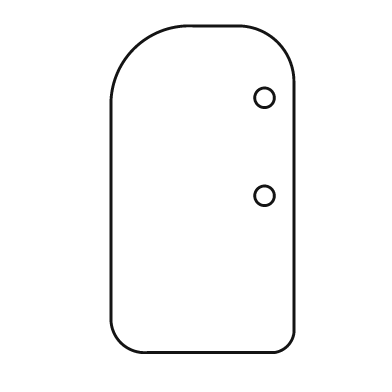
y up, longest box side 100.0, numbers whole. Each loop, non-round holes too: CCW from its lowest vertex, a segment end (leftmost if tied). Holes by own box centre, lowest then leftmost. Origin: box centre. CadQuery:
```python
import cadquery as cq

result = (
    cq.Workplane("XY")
    .moveTo(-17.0, -50.0)
    .lineTo(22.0, -50.0)
    .threePointArc((26.0, -48.0), (28.0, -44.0))
    .lineTo(28.0, 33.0)
    .threePointArc((23.0, 45.0), (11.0, 50.0))
    .lineTo(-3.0, 50.0)
    .threePointArc((-21.0, 43.0), (-28.0, 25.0))
    .lineTo(-28.0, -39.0)
    .threePointArc((-25.0, -47.0), (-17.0, -50.0))
    .close()
    .moveTo(19.0, -2.0)
    .circle(3.0)
    .moveTo(19.0, 28.0)
    .circle(3.0)
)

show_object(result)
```